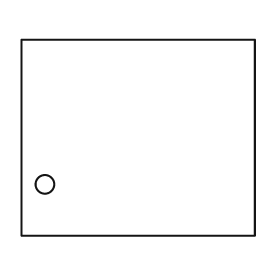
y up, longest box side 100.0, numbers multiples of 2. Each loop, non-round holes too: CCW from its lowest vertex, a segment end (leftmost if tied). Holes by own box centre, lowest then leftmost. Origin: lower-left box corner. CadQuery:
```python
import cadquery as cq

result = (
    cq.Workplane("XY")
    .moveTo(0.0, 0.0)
    .lineTo(100.0, 0.0)
    .lineTo(100.0, 84.0)
    .lineTo(0.0, 84.0)
    .close()
    .moveTo(10.0, 22.0)
    .circle(4.0)
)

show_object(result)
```